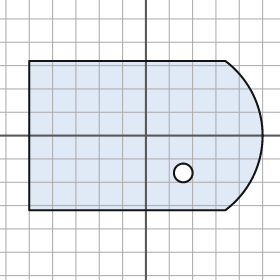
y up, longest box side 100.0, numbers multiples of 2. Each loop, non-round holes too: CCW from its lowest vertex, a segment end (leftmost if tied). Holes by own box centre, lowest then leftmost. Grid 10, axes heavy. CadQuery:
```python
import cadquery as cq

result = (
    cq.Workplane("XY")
    .moveTo(-50.0, -32.0)
    .lineTo(34.0, -32.0)
    .threePointArc((50.0, 0.0), (34.0, 32.0))
    .lineTo(-50.0, 32.0)
    .close()
    .moveTo(16.0, -16.0)
    .circle(4.0)
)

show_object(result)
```